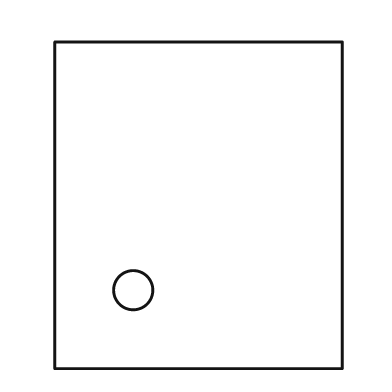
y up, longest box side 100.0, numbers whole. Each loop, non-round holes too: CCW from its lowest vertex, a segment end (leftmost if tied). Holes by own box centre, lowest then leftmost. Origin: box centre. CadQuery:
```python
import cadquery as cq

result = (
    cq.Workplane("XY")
    .moveTo(-44.0, -50.0)
    .lineTo(44.0, -50.0)
    .lineTo(44.0, 50.0)
    .lineTo(-44.0, 50.0)
    .close()
    .moveTo(-20.0, -26.0)
    .circle(6.0)
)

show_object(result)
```